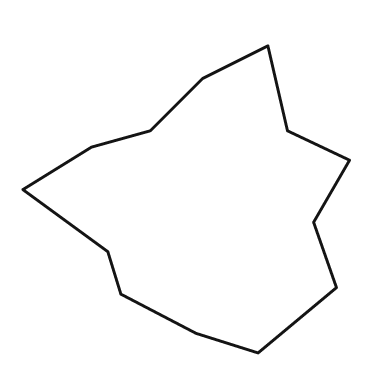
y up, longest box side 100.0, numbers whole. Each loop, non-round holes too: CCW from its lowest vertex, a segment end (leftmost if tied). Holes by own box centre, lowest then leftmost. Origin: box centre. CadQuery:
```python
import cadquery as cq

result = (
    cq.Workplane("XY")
    .moveTo(22.0, -47.0)
    .lineTo(46.0, -27.0)
    .lineTo(39.0, -7.0)
    .lineTo(50.0, 12.0)
    .lineTo(31.0, 21.0)
    .lineTo(25.0, 47.0)
    .lineTo(5.0, 37.0)
    .lineTo(-11.0, 21.0)
    .lineTo(-29.0, 16.0)
    .lineTo(-50.0, 3.0)
    .lineTo(-24.0, -16.0)
    .lineTo(-20.0, -29.0)
    .lineTo(3.0, -41.0)
    .close()
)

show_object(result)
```